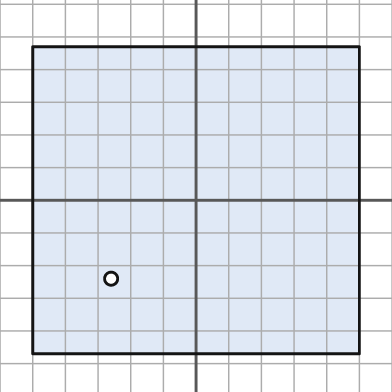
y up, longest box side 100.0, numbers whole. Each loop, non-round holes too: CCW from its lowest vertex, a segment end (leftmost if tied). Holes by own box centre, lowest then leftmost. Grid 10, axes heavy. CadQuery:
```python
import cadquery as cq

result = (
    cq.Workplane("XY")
    .moveTo(-50.0, -47.0)
    .lineTo(50.0, -47.0)
    .lineTo(50.0, 47.0)
    .lineTo(-50.0, 47.0)
    .close()
    .moveTo(-26.0, -24.0)
    .circle(2.0)
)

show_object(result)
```